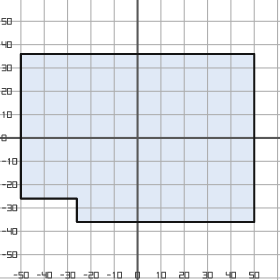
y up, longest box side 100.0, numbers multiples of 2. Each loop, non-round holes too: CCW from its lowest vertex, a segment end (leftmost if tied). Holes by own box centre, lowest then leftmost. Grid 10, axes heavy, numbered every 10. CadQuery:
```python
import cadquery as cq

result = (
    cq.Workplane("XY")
    .moveTo(-26.0, -36.0)
    .lineTo(50.0, -36.0)
    .lineTo(50.0, 36.0)
    .lineTo(-50.0, 36.0)
    .lineTo(-50.0, -26.0)
    .lineTo(-26.0, -26.0)
    .close()
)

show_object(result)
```